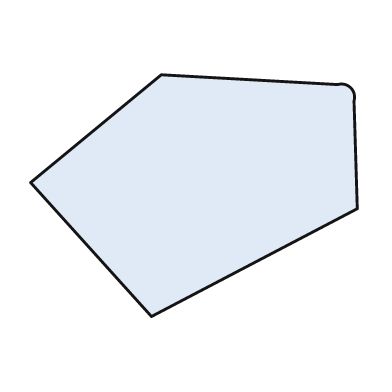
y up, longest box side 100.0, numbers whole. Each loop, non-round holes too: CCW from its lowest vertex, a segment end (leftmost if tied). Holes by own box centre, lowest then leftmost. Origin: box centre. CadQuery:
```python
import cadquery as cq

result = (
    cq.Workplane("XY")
    .moveTo(-13.0, -37.0)
    .lineTo(50.0, -4.0)
    .lineTo(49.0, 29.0)
    .threePointArc((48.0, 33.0), (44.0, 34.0))
    .lineTo(-10.0, 37.0)
    .lineTo(-50.0, 4.0)
    .close()
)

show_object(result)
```